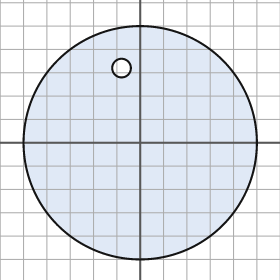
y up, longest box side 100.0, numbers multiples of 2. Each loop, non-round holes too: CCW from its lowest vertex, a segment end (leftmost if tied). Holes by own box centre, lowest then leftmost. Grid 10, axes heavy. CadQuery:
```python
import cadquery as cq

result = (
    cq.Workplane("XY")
    .moveTo(0.0, 0.0)
    .circle(50.0)
    .moveTo(-8.0, 32.0)
    .circle(4.0)
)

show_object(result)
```